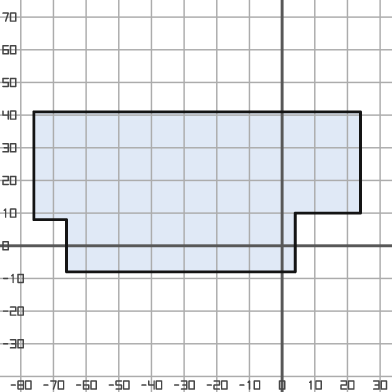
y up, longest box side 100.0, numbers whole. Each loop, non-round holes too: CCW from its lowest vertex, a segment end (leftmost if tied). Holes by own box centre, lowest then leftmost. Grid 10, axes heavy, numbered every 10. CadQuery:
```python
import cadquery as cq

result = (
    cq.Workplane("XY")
    .moveTo(-66.0, -8.0)
    .lineTo(4.0, -8.0)
    .lineTo(4.0, 10.0)
    .lineTo(24.0, 10.0)
    .lineTo(24.0, 41.0)
    .lineTo(-76.0, 41.0)
    .lineTo(-76.0, 8.0)
    .lineTo(-66.0, 8.0)
    .close()
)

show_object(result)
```